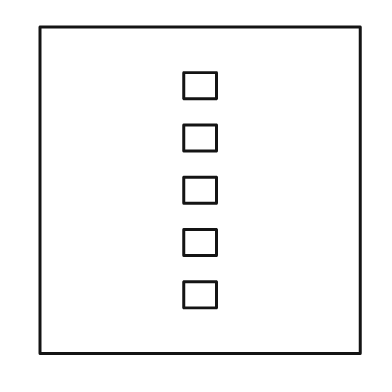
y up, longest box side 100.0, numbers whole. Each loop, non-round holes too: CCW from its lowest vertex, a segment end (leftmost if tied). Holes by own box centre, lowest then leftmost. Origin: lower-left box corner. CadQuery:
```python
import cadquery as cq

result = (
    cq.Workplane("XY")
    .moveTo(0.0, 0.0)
    .lineTo(98.0, 0.0)
    .lineTo(98.0, 100.0)
    .lineTo(0.0, 100.0)
    .close()
    .moveTo(44.0, 14.0)
    .lineTo(54.0, 14.0)
    .lineTo(54.0, 22.0)
    .lineTo(44.0, 22.0)
    .close()
    .moveTo(44.0, 30.0)
    .lineTo(54.0, 30.0)
    .lineTo(54.0, 38.0)
    .lineTo(44.0, 38.0)
    .close()
    .moveTo(44.0, 46.0)
    .lineTo(54.0, 46.0)
    .lineTo(54.0, 54.0)
    .lineTo(44.0, 54.0)
    .close()
    .moveTo(44.0, 62.0)
    .lineTo(54.0, 62.0)
    .lineTo(54.0, 70.0)
    .lineTo(44.0, 70.0)
    .close()
    .moveTo(44.0, 78.0)
    .lineTo(54.0, 78.0)
    .lineTo(54.0, 86.0)
    .lineTo(44.0, 86.0)
    .close()
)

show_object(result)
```